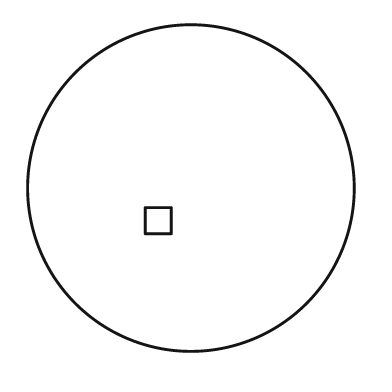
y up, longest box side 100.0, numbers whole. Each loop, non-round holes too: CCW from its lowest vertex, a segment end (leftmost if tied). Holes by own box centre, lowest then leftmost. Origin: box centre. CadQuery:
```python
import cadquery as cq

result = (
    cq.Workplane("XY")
    .moveTo(0.0, 0.0)
    .circle(50.0)
    .moveTo(-14.0, -14.0)
    .lineTo(-6.0, -14.0)
    .lineTo(-6.0, -6.0)
    .lineTo(-14.0, -6.0)
    .close()
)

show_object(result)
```